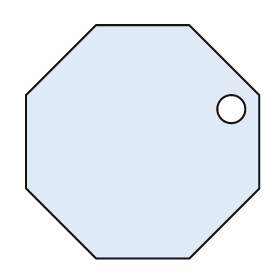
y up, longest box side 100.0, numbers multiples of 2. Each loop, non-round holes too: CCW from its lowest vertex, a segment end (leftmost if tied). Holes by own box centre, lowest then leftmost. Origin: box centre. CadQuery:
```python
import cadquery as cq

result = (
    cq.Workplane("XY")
    .moveTo(-20.0, -50.0)
    .lineTo(20.0, -50.0)
    .lineTo(50.0, -20.0)
    .lineTo(50.0, 20.0)
    .lineTo(20.0, 50.0)
    .lineTo(-20.0, 50.0)
    .lineTo(-50.0, 20.0)
    .lineTo(-50.0, -20.0)
    .close()
    .moveTo(38.0, 14.0)
    .circle(6.0)
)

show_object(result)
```